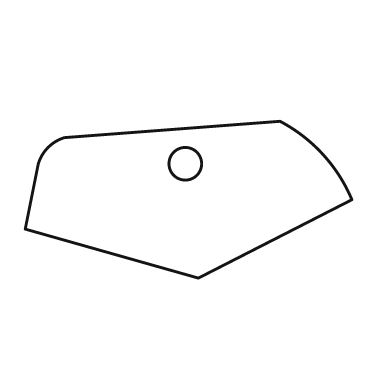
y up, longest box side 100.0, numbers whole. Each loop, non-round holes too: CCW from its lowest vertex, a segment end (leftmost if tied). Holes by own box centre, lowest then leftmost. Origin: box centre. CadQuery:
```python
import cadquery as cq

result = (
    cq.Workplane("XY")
    .moveTo(3.0, -24.0)
    .lineTo(50.0, 0.0)
    .threePointArc((41.0, 14.0), (28.0, 24.0))
    .lineTo(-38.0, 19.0)
    .threePointArc((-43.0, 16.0), (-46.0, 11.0))
    .lineTo(-50.0, -9.0)
    .close()
    .moveTo(-1.0, 11.0)
    .circle(5.0)
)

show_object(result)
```